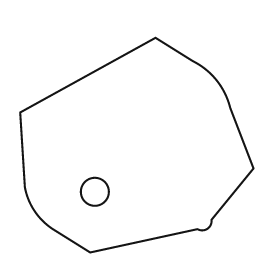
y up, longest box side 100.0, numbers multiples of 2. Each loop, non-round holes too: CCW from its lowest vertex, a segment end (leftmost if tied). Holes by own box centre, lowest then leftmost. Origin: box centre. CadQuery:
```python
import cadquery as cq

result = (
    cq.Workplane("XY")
    .moveTo(-20.0, -46.0)
    .lineTo(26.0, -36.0)
    .threePointArc((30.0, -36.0), (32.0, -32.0))
    .lineTo(50.0, -10.0)
    .lineTo(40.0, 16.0)
    .threePointArc((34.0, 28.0), (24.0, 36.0))
    .lineTo(8.0, 46.0)
    .lineTo(-50.0, 14.0)
    .lineTo(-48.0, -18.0)
    .threePointArc((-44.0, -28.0), (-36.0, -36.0))
    .close()
    .moveTo(-18.0, -20.0)
    .circle(6.0)
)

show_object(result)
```